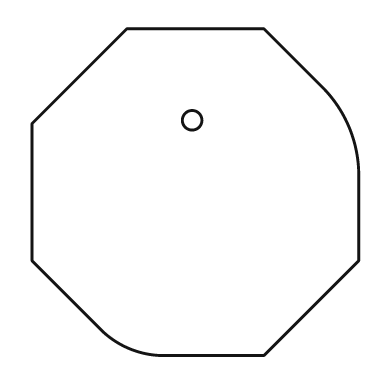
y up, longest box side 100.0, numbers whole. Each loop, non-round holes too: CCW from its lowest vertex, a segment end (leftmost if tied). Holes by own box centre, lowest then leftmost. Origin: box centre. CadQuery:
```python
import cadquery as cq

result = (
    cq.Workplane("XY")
    .moveTo(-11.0, -50.0)
    .lineTo(21.0, -50.0)
    .lineTo(50.0, -21.0)
    .lineTo(50.0, 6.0)
    .threePointArc((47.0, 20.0), (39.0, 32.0))
    .lineTo(21.0, 50.0)
    .lineTo(-21.0, 50.0)
    .lineTo(-50.0, 21.0)
    .lineTo(-50.0, -21.0)
    .lineTo(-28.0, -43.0)
    .threePointArc((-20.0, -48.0), (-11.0, -50.0))
    .close()
    .moveTo(-1.0, 22.0)
    .circle(3.0)
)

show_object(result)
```